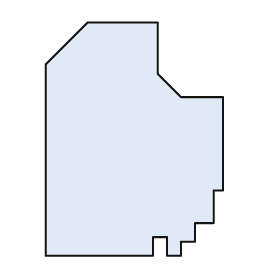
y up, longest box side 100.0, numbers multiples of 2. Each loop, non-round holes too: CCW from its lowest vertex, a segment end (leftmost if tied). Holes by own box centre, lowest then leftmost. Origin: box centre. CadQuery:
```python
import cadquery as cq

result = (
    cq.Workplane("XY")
    .moveTo(-38.0, -50.0)
    .lineTo(8.0, -50.0)
    .lineTo(8.0, -42.0)
    .lineTo(14.0, -42.0)
    .lineTo(14.0, -50.0)
    .lineTo(20.0, -50.0)
    .lineTo(20.0, -44.0)
    .lineTo(26.0, -44.0)
    .lineTo(26.0, -36.0)
    .lineTo(34.0, -36.0)
    .lineTo(34.0, -22.0)
    .lineTo(38.0, -22.0)
    .lineTo(38.0, 18.0)
    .lineTo(20.0, 18.0)
    .lineTo(10.0, 28.0)
    .lineTo(10.0, 50.0)
    .lineTo(-20.0, 50.0)
    .lineTo(-38.0, 32.0)
    .close()
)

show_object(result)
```